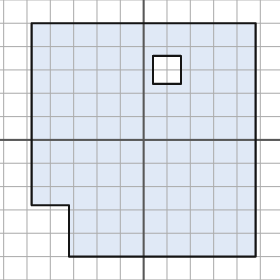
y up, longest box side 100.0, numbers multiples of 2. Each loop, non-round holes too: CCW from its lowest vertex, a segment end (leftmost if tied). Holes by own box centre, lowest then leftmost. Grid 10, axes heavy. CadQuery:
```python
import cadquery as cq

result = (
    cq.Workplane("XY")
    .moveTo(-32.0, -50.0)
    .lineTo(48.0, -50.0)
    .lineTo(48.0, 50.0)
    .lineTo(-48.0, 50.0)
    .lineTo(-48.0, -28.0)
    .lineTo(-32.0, -28.0)
    .close()
    .moveTo(4.0, 24.0)
    .lineTo(16.0, 24.0)
    .lineTo(16.0, 36.0)
    .lineTo(4.0, 36.0)
    .close()
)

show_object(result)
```